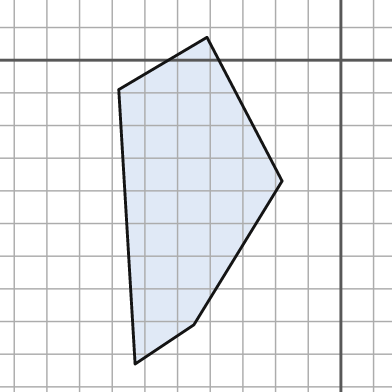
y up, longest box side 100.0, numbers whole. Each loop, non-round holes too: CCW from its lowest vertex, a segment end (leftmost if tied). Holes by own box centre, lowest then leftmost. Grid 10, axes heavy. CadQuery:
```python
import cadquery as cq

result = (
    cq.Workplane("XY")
    .moveTo(-63.0, -93.0)
    .lineTo(-45.0, -81.0)
    .lineTo(-18.0, -37.0)
    .lineTo(-41.0, 7.0)
    .lineTo(-68.0, -9.0)
    .close()
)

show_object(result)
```